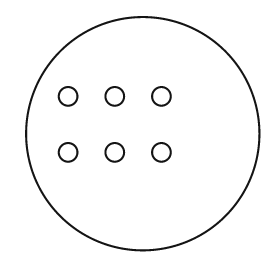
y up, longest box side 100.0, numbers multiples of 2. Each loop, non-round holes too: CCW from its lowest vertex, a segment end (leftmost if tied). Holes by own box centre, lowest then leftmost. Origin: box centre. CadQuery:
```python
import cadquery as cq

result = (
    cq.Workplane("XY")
    .moveTo(0.0, 0.0)
    .circle(50.0)
    .moveTo(-32.0, -8.0)
    .circle(4.0)
    .moveTo(-12.0, -8.0)
    .circle(4.0)
    .moveTo(8.0, -8.0)
    .circle(4.0)
    .moveTo(-32.0, 16.0)
    .circle(4.0)
    .moveTo(-12.0, 16.0)
    .circle(4.0)
    .moveTo(8.0, 16.0)
    .circle(4.0)
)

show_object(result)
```